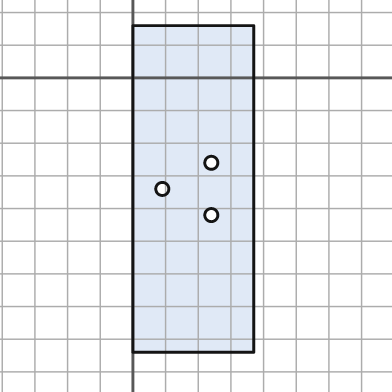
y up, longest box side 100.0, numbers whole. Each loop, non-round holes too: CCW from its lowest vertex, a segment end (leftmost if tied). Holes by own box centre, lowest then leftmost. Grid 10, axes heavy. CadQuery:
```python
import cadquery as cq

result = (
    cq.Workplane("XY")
    .moveTo(0.0, -84.0)
    .lineTo(37.0, -84.0)
    .lineTo(37.0, 16.0)
    .lineTo(0.0, 16.0)
    .close()
    .moveTo(24.0, -42.0)
    .circle(2.0)
    .moveTo(9.0, -34.0)
    .circle(2.0)
    .moveTo(24.0, -26.0)
    .circle(2.0)
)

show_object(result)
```